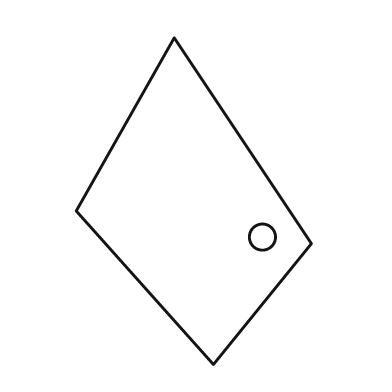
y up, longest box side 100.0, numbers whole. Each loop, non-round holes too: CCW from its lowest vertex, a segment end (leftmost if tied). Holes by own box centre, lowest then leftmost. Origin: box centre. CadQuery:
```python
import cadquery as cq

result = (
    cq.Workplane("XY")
    .moveTo(6.0, -50.0)
    .lineTo(36.0, -13.0)
    .lineTo(-6.0, 50.0)
    .lineTo(-36.0, -3.0)
    .close()
    .moveTo(21.0, -11.0)
    .circle(4.0)
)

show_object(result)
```